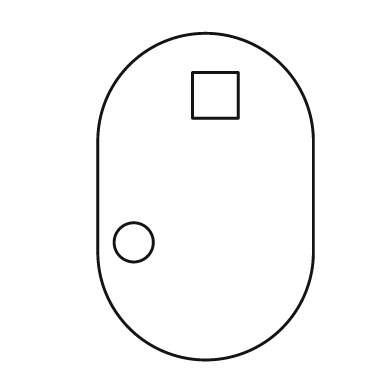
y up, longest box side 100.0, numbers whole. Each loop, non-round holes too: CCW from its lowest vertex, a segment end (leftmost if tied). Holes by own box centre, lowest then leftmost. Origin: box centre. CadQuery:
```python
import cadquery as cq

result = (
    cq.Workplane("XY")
    .moveTo(-33.0, -17.0)
    .threePointArc((0.0, -50.0), (33.0, -17.0))
    .lineTo(33.0, 17.0)
    .threePointArc((0.0, 50.0), (-33.0, 17.0))
    .close()
    .moveTo(-22.0, -14.0)
    .circle(6.0)
    .moveTo(-4.0, 24.0)
    .lineTo(10.0, 24.0)
    .lineTo(10.0, 38.0)
    .lineTo(-4.0, 38.0)
    .close()
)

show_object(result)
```